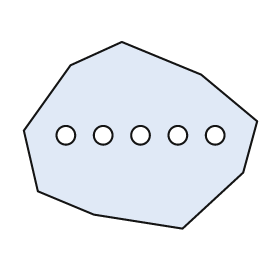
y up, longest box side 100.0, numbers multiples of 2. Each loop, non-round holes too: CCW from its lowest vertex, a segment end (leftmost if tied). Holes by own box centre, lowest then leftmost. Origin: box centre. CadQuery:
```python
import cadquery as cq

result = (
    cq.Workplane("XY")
    .moveTo(18.0, -40.0)
    .lineTo(44.0, -16.0)
    .lineTo(50.0, 6.0)
    .lineTo(26.0, 26.0)
    .lineTo(-8.0, 40.0)
    .lineTo(-30.0, 30.0)
    .lineTo(-50.0, 2.0)
    .lineTo(-44.0, -24.0)
    .lineTo(-20.0, -34.0)
    .close()
    .moveTo(-32.0, 0.0)
    .circle(4.0)
    .moveTo(-16.0, 0.0)
    .circle(4.0)
    .moveTo(0.0, 0.0)
    .circle(4.0)
    .moveTo(16.0, 0.0)
    .circle(4.0)
    .moveTo(32.0, 0.0)
    .circle(4.0)
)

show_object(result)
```